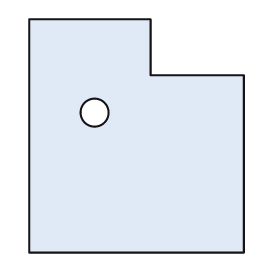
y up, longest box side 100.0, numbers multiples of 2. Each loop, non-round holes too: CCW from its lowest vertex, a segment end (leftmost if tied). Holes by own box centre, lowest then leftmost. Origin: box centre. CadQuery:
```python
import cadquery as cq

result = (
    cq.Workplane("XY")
    .moveTo(-46.0, -50.0)
    .lineTo(46.0, -50.0)
    .lineTo(46.0, 26.0)
    .lineTo(6.0, 26.0)
    .lineTo(6.0, 50.0)
    .lineTo(-46.0, 50.0)
    .close()
    .moveTo(-18.0, 10.0)
    .circle(6.0)
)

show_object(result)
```